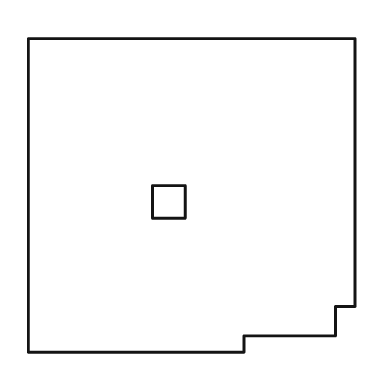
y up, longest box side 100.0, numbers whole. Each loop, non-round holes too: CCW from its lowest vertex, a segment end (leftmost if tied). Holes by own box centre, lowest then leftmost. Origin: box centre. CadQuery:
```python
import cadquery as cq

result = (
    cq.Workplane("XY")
    .moveTo(-50.0, -48.0)
    .lineTo(16.0, -48.0)
    .lineTo(16.0, -43.0)
    .lineTo(44.0, -43.0)
    .lineTo(44.0, -34.0)
    .lineTo(50.0, -34.0)
    .lineTo(50.0, 48.0)
    .lineTo(-50.0, 48.0)
    .close()
    .moveTo(-12.0, -7.0)
    .lineTo(-2.0, -7.0)
    .lineTo(-2.0, 3.0)
    .lineTo(-12.0, 3.0)
    .close()
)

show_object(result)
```